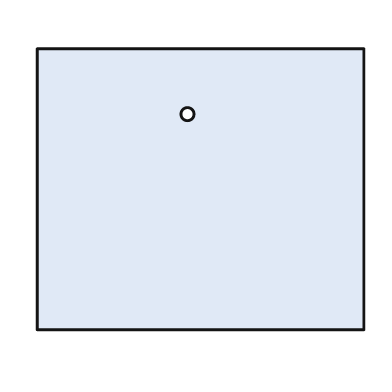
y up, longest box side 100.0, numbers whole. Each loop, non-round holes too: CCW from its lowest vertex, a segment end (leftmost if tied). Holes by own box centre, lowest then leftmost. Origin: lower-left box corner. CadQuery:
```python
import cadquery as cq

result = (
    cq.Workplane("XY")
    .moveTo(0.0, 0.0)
    .lineTo(100.0, 0.0)
    .lineTo(100.0, 86.0)
    .lineTo(0.0, 86.0)
    .close()
    .moveTo(46.0, 66.0)
    .circle(2.0)
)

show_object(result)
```